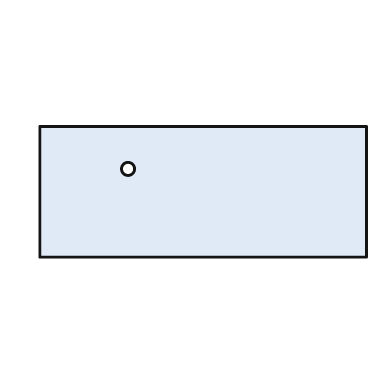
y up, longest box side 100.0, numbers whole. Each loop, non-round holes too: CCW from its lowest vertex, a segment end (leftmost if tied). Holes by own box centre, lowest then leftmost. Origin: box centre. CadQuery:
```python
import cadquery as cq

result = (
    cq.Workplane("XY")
    .moveTo(-50.0, -20.0)
    .lineTo(50.0, -20.0)
    .lineTo(50.0, 20.0)
    .lineTo(-50.0, 20.0)
    .close()
    .moveTo(-23.0, 7.0)
    .circle(2.0)
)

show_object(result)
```